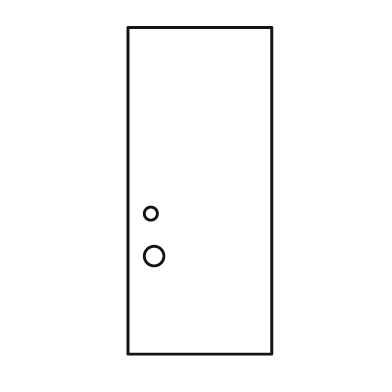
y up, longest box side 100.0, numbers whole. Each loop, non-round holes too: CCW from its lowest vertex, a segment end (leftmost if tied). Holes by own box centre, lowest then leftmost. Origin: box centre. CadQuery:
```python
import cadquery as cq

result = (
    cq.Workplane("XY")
    .moveTo(-22.0, -50.0)
    .lineTo(22.0, -50.0)
    .lineTo(22.0, 50.0)
    .lineTo(-22.0, 50.0)
    .close()
    .moveTo(-14.0, -20.0)
    .circle(3.0)
    .moveTo(-15.0, -7.0)
    .circle(2.0)
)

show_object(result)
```